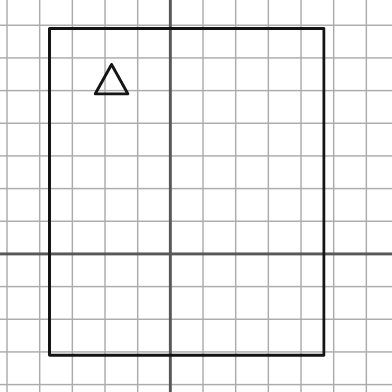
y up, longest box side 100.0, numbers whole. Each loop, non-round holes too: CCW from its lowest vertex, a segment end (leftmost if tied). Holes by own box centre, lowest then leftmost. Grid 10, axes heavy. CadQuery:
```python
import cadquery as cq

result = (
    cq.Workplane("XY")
    .moveTo(-37.0, -31.0)
    .lineTo(47.0, -31.0)
    .lineTo(47.0, 69.0)
    .lineTo(-37.0, 69.0)
    .close()
    .moveTo(-23.0, 49.0)
    .lineTo(-13.0, 49.0)
    .lineTo(-18.0, 58.0)
    .close()
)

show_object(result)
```